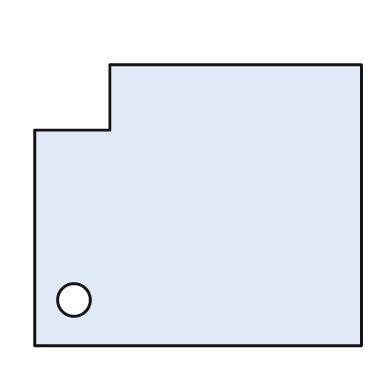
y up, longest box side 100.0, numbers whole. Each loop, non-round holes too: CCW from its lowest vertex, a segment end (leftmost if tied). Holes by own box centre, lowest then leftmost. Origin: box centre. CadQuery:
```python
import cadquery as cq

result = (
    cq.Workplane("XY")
    .moveTo(-50.0, -43.0)
    .lineTo(50.0, -43.0)
    .lineTo(50.0, 43.0)
    .lineTo(-27.0, 43.0)
    .lineTo(-27.0, 23.0)
    .lineTo(-50.0, 23.0)
    .close()
    .moveTo(-38.0, -29.0)
    .circle(5.0)
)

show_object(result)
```